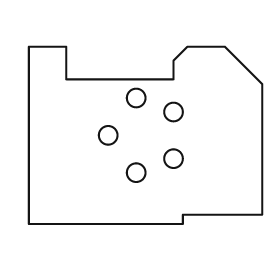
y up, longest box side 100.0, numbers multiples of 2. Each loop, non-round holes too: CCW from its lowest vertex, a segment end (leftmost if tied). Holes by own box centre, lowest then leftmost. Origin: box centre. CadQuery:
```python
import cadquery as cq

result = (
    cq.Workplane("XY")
    .moveTo(-50.0, -38.0)
    .lineTo(16.0, -38.0)
    .lineTo(16.0, -34.0)
    .lineTo(50.0, -34.0)
    .lineTo(50.0, 22.0)
    .lineTo(34.0, 38.0)
    .lineTo(18.0, 38.0)
    .lineTo(12.0, 32.0)
    .lineTo(12.0, 24.0)
    .lineTo(-34.0, 24.0)
    .lineTo(-34.0, 38.0)
    .lineTo(-50.0, 38.0)
    .close()
    .moveTo(-4.0, -16.0)
    .circle(4.0)
    .moveTo(12.0, -10.0)
    .circle(4.0)
    .moveTo(-16.0, 0.0)
    .circle(4.0)
    .moveTo(12.0, 10.0)
    .circle(4.0)
    .moveTo(-4.0, 16.0)
    .circle(4.0)
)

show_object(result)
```